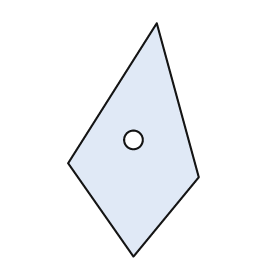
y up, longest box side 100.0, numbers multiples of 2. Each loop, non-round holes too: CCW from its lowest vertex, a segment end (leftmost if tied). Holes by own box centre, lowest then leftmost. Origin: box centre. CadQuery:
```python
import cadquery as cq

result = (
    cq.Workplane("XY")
    .moveTo(0.0, -50.0)
    .lineTo(28.0, -16.0)
    .lineTo(10.0, 50.0)
    .lineTo(-28.0, -10.0)
    .close()
    .moveTo(0.0, 0.0)
    .circle(4.0)
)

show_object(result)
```